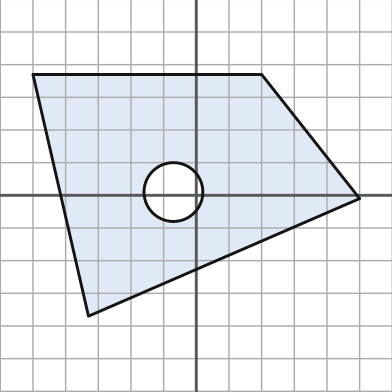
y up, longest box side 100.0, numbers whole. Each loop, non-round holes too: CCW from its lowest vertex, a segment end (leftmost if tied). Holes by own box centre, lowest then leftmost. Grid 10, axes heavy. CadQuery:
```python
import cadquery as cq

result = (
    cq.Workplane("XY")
    .moveTo(-33.0, -37.0)
    .lineTo(50.0, -1.0)
    .lineTo(20.0, 37.0)
    .lineTo(-50.0, 37.0)
    .close()
    .moveTo(-7.0, 1.0)
    .circle(9.0)
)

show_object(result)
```